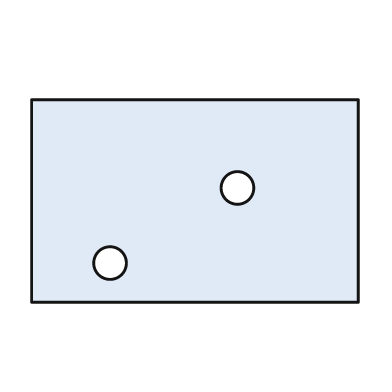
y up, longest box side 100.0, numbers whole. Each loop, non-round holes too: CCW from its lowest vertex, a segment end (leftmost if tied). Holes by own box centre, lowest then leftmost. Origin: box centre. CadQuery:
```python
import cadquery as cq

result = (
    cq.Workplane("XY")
    .moveTo(-50.0, -31.0)
    .lineTo(50.0, -31.0)
    .lineTo(50.0, 31.0)
    .lineTo(-50.0, 31.0)
    .close()
    .moveTo(-26.0, -19.0)
    .circle(5.0)
    .moveTo(13.0, 4.0)
    .circle(5.0)
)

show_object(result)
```